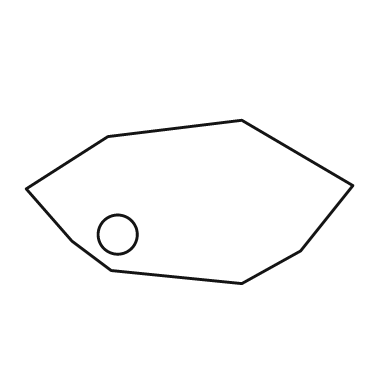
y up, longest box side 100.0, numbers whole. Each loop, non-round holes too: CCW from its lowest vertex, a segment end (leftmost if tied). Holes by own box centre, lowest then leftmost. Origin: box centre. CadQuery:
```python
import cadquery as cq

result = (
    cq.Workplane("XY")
    .moveTo(16.0, -25.0)
    .lineTo(34.0, -15.0)
    .lineTo(50.0, 5.0)
    .lineTo(16.0, 25.0)
    .lineTo(-25.0, 20.0)
    .lineTo(-50.0, 4.0)
    .lineTo(-36.0, -12.0)
    .lineTo(-24.0, -21.0)
    .close()
    .moveTo(-22.0, -10.0)
    .circle(6.0)
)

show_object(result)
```